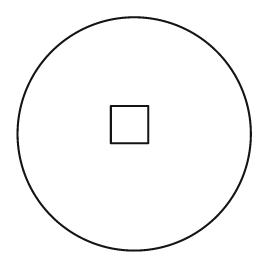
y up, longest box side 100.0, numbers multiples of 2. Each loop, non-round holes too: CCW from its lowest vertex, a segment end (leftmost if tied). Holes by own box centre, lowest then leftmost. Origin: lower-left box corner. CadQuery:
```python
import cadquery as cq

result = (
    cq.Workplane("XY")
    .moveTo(50.0, 50.0)
    .circle(50.0)
    .moveTo(40.0, 46.0)
    .lineTo(56.0, 46.0)
    .lineTo(56.0, 62.0)
    .lineTo(40.0, 62.0)
    .close()
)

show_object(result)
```